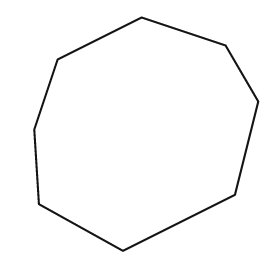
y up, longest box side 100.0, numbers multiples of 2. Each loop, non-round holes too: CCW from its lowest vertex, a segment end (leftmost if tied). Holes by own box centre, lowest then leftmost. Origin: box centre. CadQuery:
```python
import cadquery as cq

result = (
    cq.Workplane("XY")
    .moveTo(-10.0, -50.0)
    .lineTo(38.0, -26.0)
    .lineTo(48.0, 14.0)
    .lineTo(34.0, 38.0)
    .lineTo(-2.0, 50.0)
    .lineTo(-38.0, 32.0)
    .lineTo(-48.0, 2.0)
    .lineTo(-46.0, -30.0)
    .close()
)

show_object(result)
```